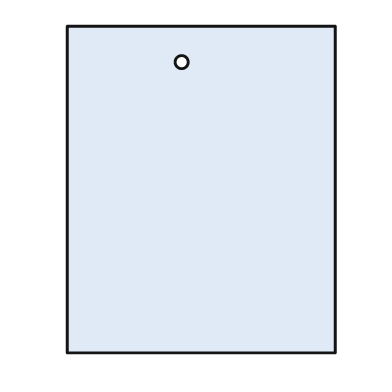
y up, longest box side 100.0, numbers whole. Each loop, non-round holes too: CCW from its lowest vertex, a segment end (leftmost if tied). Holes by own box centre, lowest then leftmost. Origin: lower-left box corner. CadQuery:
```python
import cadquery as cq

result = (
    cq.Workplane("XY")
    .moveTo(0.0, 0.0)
    .lineTo(82.0, 0.0)
    .lineTo(82.0, 100.0)
    .lineTo(0.0, 100.0)
    .close()
    .moveTo(35.0, 89.0)
    .circle(2.0)
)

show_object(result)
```